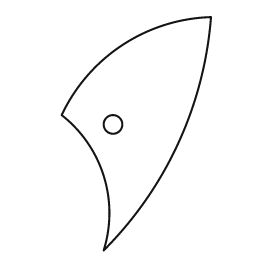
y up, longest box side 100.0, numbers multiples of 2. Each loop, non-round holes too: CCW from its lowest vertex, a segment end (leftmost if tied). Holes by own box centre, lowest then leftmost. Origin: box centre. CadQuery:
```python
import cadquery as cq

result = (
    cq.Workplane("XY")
    .moveTo(-14.0, -50.0)
    .threePointArc((18.0, -4.0), (32.0, 50.0))
    .threePointArc((-6.0, 38.0), (-32.0, 8.0))
    .threePointArc((-14.0, -18.0), (-14.0, -50.0))
    .close()
    .moveTo(-10.0, 4.0)
    .circle(4.0)
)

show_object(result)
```